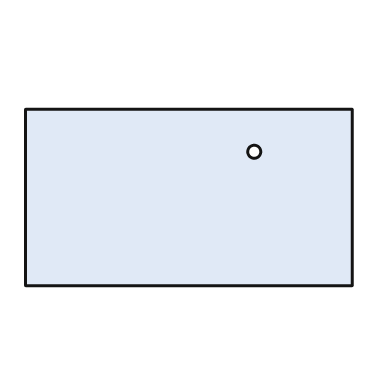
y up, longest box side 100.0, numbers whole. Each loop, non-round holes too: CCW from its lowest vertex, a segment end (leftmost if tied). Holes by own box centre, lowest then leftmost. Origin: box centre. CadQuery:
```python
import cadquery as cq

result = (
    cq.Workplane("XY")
    .moveTo(-50.0, -27.0)
    .lineTo(50.0, -27.0)
    .lineTo(50.0, 27.0)
    .lineTo(-50.0, 27.0)
    .close()
    .moveTo(20.0, 14.0)
    .circle(2.0)
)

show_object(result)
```